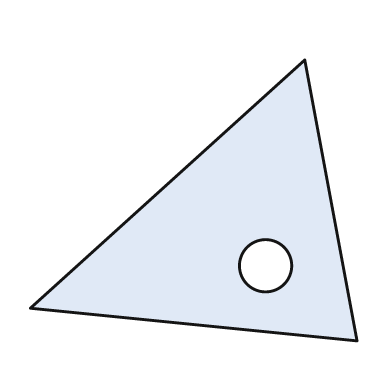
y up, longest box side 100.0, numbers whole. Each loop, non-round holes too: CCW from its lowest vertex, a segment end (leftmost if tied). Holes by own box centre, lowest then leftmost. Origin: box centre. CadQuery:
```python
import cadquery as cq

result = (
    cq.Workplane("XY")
    .moveTo(50.0, -43.0)
    .lineTo(34.0, 43.0)
    .lineTo(-50.0, -33.0)
    .close()
    .moveTo(22.0, -20.0)
    .circle(8.0)
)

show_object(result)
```